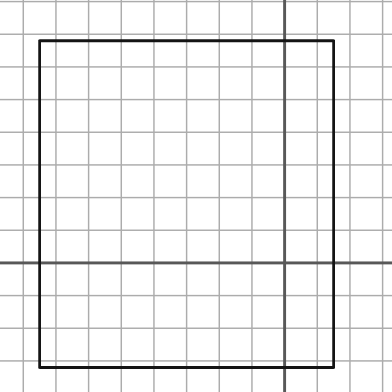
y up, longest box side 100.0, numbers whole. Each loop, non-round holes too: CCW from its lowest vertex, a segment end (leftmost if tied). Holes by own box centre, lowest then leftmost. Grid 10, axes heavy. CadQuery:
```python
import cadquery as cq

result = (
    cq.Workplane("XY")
    .moveTo(-75.0, -32.0)
    .lineTo(15.0, -32.0)
    .lineTo(15.0, 68.0)
    .lineTo(-75.0, 68.0)
    .close()
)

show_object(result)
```